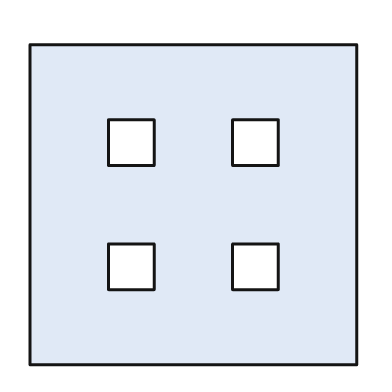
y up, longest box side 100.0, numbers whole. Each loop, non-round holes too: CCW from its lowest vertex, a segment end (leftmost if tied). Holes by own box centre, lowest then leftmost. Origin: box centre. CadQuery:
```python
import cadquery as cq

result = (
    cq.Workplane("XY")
    .moveTo(-50.0, -49.0)
    .lineTo(50.0, -49.0)
    .lineTo(50.0, 49.0)
    .lineTo(-50.0, 49.0)
    .close()
    .moveTo(-26.0, -26.0)
    .lineTo(-12.0, -26.0)
    .lineTo(-12.0, -12.0)
    .lineTo(-26.0, -12.0)
    .close()
    .moveTo(12.0, -26.0)
    .lineTo(26.0, -26.0)
    .lineTo(26.0, -12.0)
    .lineTo(12.0, -12.0)
    .close()
    .moveTo(-26.0, 12.0)
    .lineTo(-12.0, 12.0)
    .lineTo(-12.0, 26.0)
    .lineTo(-26.0, 26.0)
    .close()
    .moveTo(12.0, 12.0)
    .lineTo(26.0, 12.0)
    .lineTo(26.0, 26.0)
    .lineTo(12.0, 26.0)
    .close()
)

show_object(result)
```